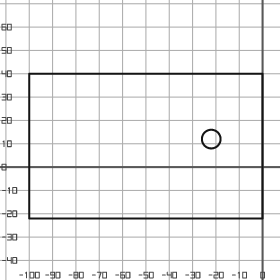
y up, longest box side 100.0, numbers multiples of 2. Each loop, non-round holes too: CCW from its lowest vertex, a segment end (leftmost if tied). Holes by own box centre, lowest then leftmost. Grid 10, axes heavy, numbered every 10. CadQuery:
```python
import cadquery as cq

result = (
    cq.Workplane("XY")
    .moveTo(-100.0, -22.0)
    .lineTo(0.0, -22.0)
    .lineTo(0.0, 40.0)
    .lineTo(-100.0, 40.0)
    .close()
    .moveTo(-22.0, 12.0)
    .circle(4.0)
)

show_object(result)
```